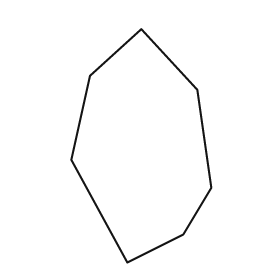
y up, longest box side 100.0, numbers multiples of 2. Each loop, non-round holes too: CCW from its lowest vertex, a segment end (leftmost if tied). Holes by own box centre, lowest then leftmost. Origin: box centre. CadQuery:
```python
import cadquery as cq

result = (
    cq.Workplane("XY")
    .moveTo(-6.0, -50.0)
    .lineTo(18.0, -38.0)
    .lineTo(30.0, -18.0)
    .lineTo(24.0, 24.0)
    .lineTo(0.0, 50.0)
    .lineTo(-22.0, 30.0)
    .lineTo(-30.0, -6.0)
    .close()
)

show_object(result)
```